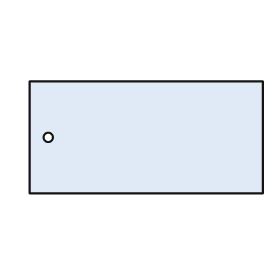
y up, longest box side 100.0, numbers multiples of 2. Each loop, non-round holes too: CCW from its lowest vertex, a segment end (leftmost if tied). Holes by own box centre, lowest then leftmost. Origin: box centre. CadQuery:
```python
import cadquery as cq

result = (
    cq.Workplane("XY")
    .moveTo(-50.0, -24.0)
    .lineTo(50.0, -24.0)
    .lineTo(50.0, 24.0)
    .lineTo(-50.0, 24.0)
    .close()
    .moveTo(-42.0, 0.0)
    .circle(2.0)
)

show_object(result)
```